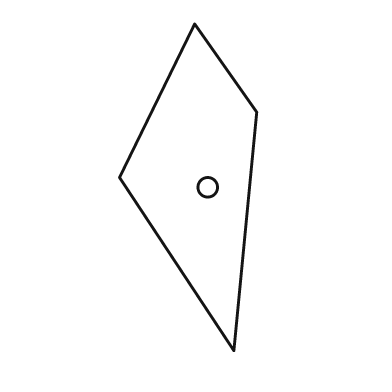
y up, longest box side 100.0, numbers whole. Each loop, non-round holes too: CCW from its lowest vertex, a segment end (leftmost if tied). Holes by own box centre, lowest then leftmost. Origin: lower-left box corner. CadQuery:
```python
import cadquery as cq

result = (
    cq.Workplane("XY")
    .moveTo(35.0, 0.0)
    .lineTo(42.0, 73.0)
    .lineTo(23.0, 100.0)
    .lineTo(0.0, 53.0)
    .close()
    .moveTo(27.0, 50.0)
    .circle(3.0)
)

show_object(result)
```